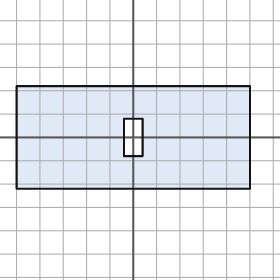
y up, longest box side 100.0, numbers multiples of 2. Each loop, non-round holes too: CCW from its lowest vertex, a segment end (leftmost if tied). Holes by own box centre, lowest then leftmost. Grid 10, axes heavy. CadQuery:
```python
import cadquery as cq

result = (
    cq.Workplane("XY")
    .moveTo(-50.0, -22.0)
    .lineTo(50.0, -22.0)
    .lineTo(50.0, 22.0)
    .lineTo(-50.0, 22.0)
    .close()
    .moveTo(-4.0, -8.0)
    .lineTo(4.0, -8.0)
    .lineTo(4.0, 8.0)
    .lineTo(-4.0, 8.0)
    .close()
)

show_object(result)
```